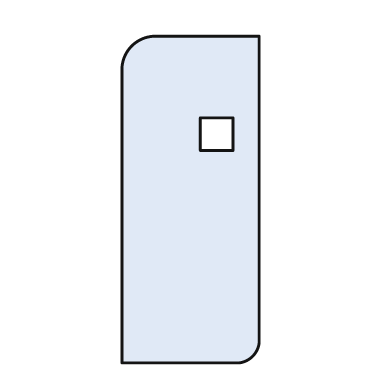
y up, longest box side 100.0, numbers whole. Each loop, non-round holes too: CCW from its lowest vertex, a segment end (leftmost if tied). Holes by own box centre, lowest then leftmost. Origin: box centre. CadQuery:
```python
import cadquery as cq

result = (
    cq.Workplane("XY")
    .moveTo(-21.0, -50.0)
    .lineTo(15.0, -50.0)
    .threePointArc((19.0, -48.0), (21.0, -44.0))
    .lineTo(21.0, 50.0)
    .lineTo(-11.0, 50.0)
    .threePointArc((-18.0, 47.0), (-21.0, 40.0))
    .close()
    .moveTo(3.0, 15.0)
    .lineTo(13.0, 15.0)
    .lineTo(13.0, 25.0)
    .lineTo(3.0, 25.0)
    .close()
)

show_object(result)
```